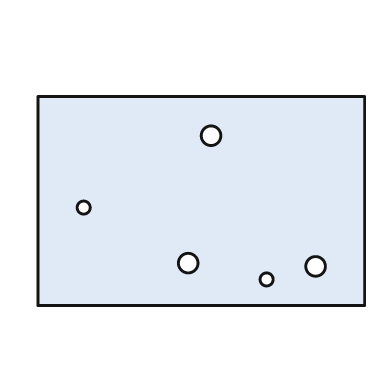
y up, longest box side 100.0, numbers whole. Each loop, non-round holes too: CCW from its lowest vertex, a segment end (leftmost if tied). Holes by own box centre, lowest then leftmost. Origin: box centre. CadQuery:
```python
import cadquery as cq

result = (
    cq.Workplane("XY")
    .moveTo(-50.0, -32.0)
    .lineTo(50.0, -32.0)
    .lineTo(50.0, 32.0)
    .lineTo(-50.0, 32.0)
    .close()
    .moveTo(20.0, -24.0)
    .circle(2.0)
    .moveTo(35.0, -20.0)
    .circle(3.0)
    .moveTo(-4.0, -19.0)
    .circle(3.0)
    .moveTo(-36.0, -2.0)
    .circle(2.0)
    .moveTo(3.0, 20.0)
    .circle(3.0)
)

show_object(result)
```